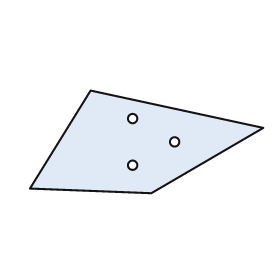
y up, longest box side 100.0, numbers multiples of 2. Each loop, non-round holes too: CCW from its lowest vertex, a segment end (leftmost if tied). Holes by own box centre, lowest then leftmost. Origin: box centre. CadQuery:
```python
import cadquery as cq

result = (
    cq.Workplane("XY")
    .moveTo(2.0, -22.0)
    .lineTo(50.0, 6.0)
    .lineTo(-24.0, 22.0)
    .lineTo(-50.0, -20.0)
    .close()
    .moveTo(-6.0, -10.0)
    .circle(2.0)
    .moveTo(12.0, 0.0)
    .circle(2.0)
    .moveTo(-6.0, 10.0)
    .circle(2.0)
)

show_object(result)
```